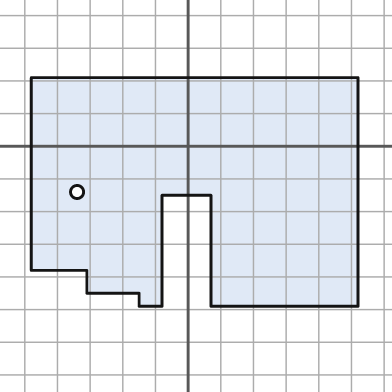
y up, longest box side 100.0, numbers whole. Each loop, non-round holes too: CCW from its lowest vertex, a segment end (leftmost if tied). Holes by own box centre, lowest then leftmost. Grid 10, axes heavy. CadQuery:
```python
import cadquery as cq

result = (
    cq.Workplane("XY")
    .moveTo(-15.0, -49.0)
    .lineTo(-8.0, -49.0)
    .lineTo(-8.0, -15.0)
    .lineTo(7.0, -15.0)
    .lineTo(7.0, -49.0)
    .lineTo(52.0, -49.0)
    .lineTo(52.0, 21.0)
    .lineTo(-48.0, 21.0)
    .lineTo(-48.0, -38.0)
    .lineTo(-31.0, -38.0)
    .lineTo(-31.0, -45.0)
    .lineTo(-15.0, -45.0)
    .close()
    .moveTo(-34.0, -14.0)
    .circle(2.0)
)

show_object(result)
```